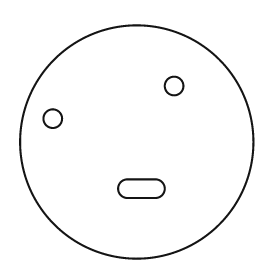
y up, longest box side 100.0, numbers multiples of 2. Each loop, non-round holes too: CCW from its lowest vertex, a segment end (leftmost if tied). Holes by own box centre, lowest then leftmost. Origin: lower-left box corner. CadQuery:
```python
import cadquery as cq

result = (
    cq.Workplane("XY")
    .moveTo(50.0, 50.0)
    .circle(50.0)
    .moveTo(46.0, 26.0)
    .lineTo(58.0, 26.0)
    .threePointArc((62.0, 30.0), (58.0, 34.0))
    .lineTo(46.0, 34.0)
    .threePointArc((42.0, 30.0), (46.0, 26.0))
    .close()
    .moveTo(14.0, 60.0)
    .circle(4.0)
    .moveTo(66.0, 74.0)
    .circle(4.0)
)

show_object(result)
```